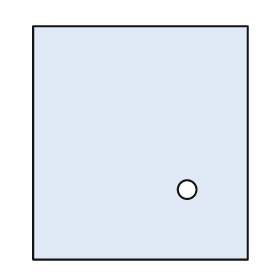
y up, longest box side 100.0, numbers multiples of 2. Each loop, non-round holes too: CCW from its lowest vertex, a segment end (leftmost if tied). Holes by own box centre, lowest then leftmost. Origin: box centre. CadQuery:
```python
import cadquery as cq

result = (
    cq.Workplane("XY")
    .moveTo(-46.0, -50.0)
    .lineTo(46.0, -50.0)
    .lineTo(46.0, 50.0)
    .lineTo(-46.0, 50.0)
    .close()
    .moveTo(20.0, -20.0)
    .circle(4.0)
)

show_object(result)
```